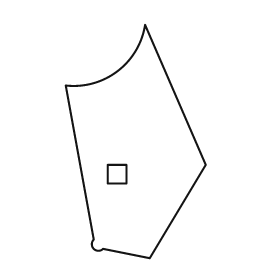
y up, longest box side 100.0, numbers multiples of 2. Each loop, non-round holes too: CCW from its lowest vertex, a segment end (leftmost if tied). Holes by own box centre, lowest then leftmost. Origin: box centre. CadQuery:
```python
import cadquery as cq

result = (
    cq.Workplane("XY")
    .moveTo(6.0, -50.0)
    .lineTo(30.0, -10.0)
    .lineTo(4.0, 50.0)
    .threePointArc((-8.0, 30.0), (-30.0, 24.0))
    .lineTo(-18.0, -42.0)
    .threePointArc((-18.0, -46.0), (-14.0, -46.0))
    .close()
    .moveTo(-12.0, -18.0)
    .lineTo(-4.0, -18.0)
    .lineTo(-4.0, -10.0)
    .lineTo(-12.0, -10.0)
    .close()
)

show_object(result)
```